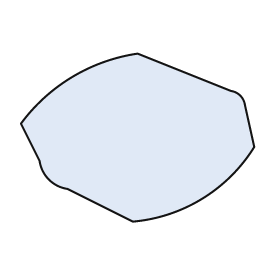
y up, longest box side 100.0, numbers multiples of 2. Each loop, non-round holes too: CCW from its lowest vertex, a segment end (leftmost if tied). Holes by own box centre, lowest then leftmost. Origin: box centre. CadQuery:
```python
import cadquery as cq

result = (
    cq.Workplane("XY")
    .moveTo(-2.0, -36.0)
    .threePointArc((28.0, -26.0), (50.0, -4.0))
    .lineTo(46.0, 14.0)
    .threePointArc((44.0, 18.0), (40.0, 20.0))
    .lineTo(0.0, 36.0)
    .threePointArc((-28.0, 26.0), (-50.0, 6.0))
    .lineTo(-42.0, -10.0)
    .threePointArc((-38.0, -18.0), (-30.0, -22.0))
    .close()
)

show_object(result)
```